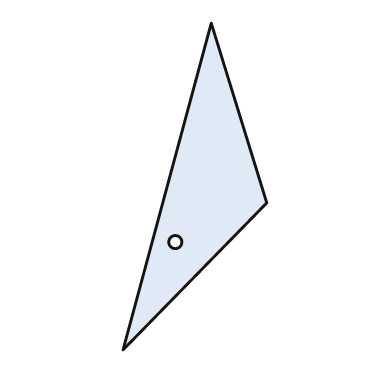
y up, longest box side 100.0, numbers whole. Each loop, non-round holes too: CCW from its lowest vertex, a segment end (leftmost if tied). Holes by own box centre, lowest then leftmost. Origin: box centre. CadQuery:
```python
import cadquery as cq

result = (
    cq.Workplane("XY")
    .moveTo(-22.0, -50.0)
    .lineTo(22.0, -5.0)
    .lineTo(5.0, 50.0)
    .close()
    .moveTo(-6.0, -17.0)
    .circle(2.0)
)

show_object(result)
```